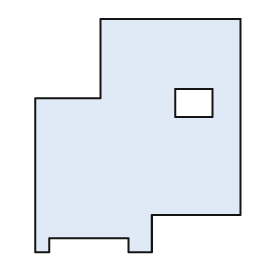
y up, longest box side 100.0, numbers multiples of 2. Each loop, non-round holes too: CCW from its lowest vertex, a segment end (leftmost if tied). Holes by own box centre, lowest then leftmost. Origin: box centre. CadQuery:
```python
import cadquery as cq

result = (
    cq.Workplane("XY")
    .moveTo(-44.0, -50.0)
    .lineTo(-38.0, -50.0)
    .lineTo(-38.0, -44.0)
    .lineTo(-4.0, -44.0)
    .lineTo(-4.0, -50.0)
    .lineTo(6.0, -50.0)
    .lineTo(6.0, -34.0)
    .lineTo(44.0, -34.0)
    .lineTo(44.0, 50.0)
    .lineTo(-16.0, 50.0)
    .lineTo(-16.0, 16.0)
    .lineTo(-44.0, 16.0)
    .close()
    .moveTo(16.0, 8.0)
    .lineTo(32.0, 8.0)
    .lineTo(32.0, 20.0)
    .lineTo(16.0, 20.0)
    .close()
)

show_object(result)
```